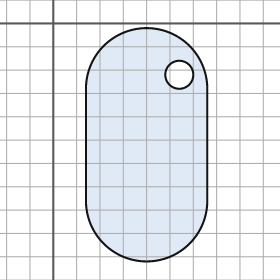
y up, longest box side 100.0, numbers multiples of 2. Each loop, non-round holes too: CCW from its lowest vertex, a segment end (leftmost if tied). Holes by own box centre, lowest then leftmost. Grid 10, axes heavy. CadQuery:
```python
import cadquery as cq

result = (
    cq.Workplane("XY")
    .moveTo(14.0, -76.0)
    .threePointArc((40.0, -102.0), (66.0, -76.0))
    .lineTo(66.0, -28.0)
    .threePointArc((40.0, -2.0), (14.0, -28.0))
    .close()
    .moveTo(54.0, -22.0)
    .circle(6.0)
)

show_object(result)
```